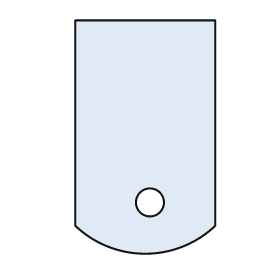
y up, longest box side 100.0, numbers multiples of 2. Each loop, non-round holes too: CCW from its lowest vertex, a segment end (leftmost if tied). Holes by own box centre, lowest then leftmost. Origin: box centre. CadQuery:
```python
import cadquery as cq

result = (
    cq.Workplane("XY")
    .moveTo(-30.0, -38.0)
    .threePointArc((0.0, -50.0), (30.0, -38.0))
    .lineTo(30.0, 50.0)
    .lineTo(-30.0, 50.0)
    .close()
    .moveTo(2.0, -28.0)
    .circle(6.0)
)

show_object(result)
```